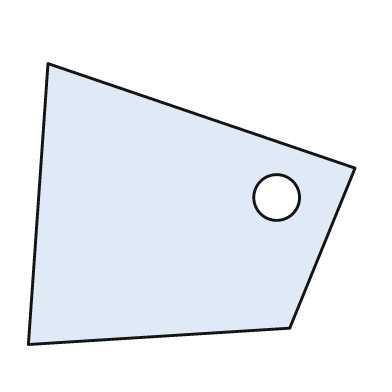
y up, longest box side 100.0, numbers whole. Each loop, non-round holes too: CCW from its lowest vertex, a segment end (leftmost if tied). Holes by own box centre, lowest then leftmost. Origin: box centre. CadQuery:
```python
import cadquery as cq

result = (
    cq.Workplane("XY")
    .moveTo(-50.0, -43.0)
    .lineTo(30.0, -38.0)
    .lineTo(50.0, 11.0)
    .lineTo(-44.0, 43.0)
    .close()
    .moveTo(26.0, 2.0)
    .circle(7.0)
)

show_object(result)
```